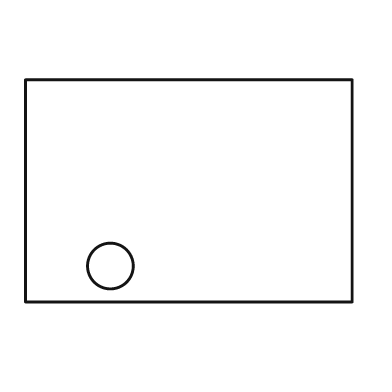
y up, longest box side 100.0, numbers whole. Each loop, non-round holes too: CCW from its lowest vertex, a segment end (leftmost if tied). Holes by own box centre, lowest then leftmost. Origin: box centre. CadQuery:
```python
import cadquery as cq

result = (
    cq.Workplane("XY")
    .moveTo(-50.0, -34.0)
    .lineTo(50.0, -34.0)
    .lineTo(50.0, 34.0)
    .lineTo(-50.0, 34.0)
    .close()
    .moveTo(-24.0, -23.0)
    .circle(7.0)
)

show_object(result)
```